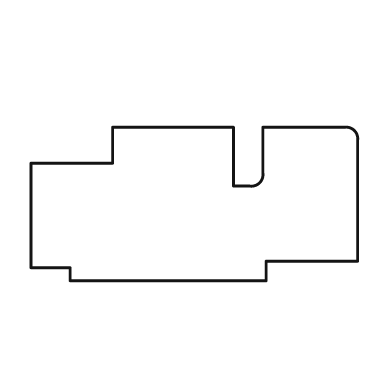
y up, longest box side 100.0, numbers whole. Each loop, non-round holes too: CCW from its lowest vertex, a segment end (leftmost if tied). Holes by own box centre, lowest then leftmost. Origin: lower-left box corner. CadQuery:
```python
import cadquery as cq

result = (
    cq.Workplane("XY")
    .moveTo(12.0, 0.0)
    .lineTo(72.0, 0.0)
    .lineTo(72.0, 6.0)
    .lineTo(100.0, 6.0)
    .lineTo(100.0, 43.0)
    .threePointArc((99.0, 46.0), (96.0, 47.0))
    .lineTo(71.0, 47.0)
    .lineTo(71.0, 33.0)
    .threePointArc((70.0, 30.0), (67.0, 29.0))
    .lineTo(62.0, 29.0)
    .lineTo(62.0, 47.0)
    .lineTo(25.0, 47.0)
    .lineTo(25.0, 36.0)
    .lineTo(0.0, 36.0)
    .lineTo(0.0, 4.0)
    .lineTo(12.0, 4.0)
    .close()
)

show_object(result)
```